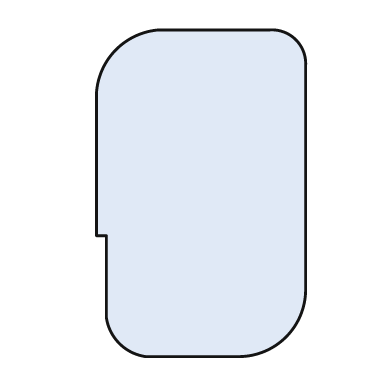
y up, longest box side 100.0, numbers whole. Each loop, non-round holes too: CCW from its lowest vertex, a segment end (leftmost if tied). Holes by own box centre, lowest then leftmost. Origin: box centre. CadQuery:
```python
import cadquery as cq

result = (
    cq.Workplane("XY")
    .moveTo(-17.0, -50.0)
    .lineTo(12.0, -50.0)
    .threePointArc((26.0, -44.0), (32.0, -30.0))
    .lineTo(32.0, 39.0)
    .threePointArc((29.0, 47.0), (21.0, 50.0))
    .lineTo(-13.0, 50.0)
    .threePointArc((-26.0, 44.0), (-32.0, 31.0))
    .lineTo(-32.0, -13.0)
    .lineTo(-29.0, -13.0)
    .lineTo(-29.0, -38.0)
    .threePointArc((-25.0, -46.0), (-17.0, -50.0))
    .close()
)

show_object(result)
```